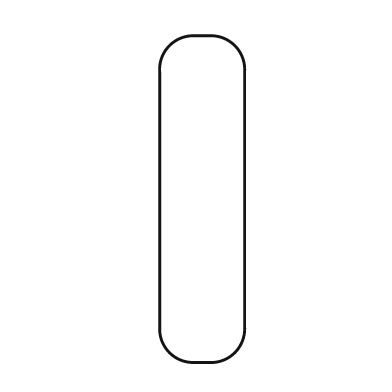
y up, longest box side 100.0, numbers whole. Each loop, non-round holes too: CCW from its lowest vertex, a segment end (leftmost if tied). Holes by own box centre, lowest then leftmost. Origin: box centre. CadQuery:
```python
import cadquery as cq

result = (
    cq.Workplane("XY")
    .moveTo(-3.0, -50.0)
    .lineTo(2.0, -50.0)
    .threePointArc((10.0, -47.0), (13.0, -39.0))
    .lineTo(13.0, 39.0)
    .threePointArc((10.0, 47.0), (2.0, 50.0))
    .lineTo(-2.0, 50.0)
    .threePointArc((-10.0, 47.0), (-13.0, 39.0))
    .lineTo(-13.0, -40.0)
    .threePointArc((-10.0, -47.0), (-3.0, -50.0))
    .close()
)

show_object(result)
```